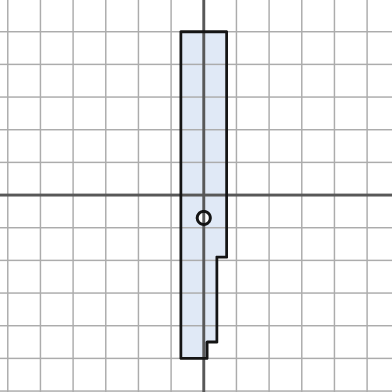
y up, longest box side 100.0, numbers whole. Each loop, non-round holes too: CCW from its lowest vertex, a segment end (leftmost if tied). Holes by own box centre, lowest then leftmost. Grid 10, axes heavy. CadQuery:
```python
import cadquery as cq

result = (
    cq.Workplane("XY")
    .moveTo(-7.0, -50.0)
    .lineTo(1.0, -50.0)
    .lineTo(1.0, -45.0)
    .lineTo(4.0, -45.0)
    .lineTo(4.0, -19.0)
    .lineTo(7.0, -19.0)
    .lineTo(7.0, 50.0)
    .lineTo(-7.0, 50.0)
    .close()
    .moveTo(0.0, -7.0)
    .circle(2.0)
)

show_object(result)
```